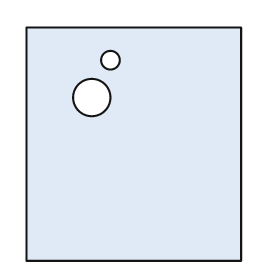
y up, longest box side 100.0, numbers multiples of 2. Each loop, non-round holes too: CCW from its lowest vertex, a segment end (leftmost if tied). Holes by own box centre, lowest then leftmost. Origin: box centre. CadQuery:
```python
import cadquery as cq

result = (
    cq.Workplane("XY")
    .moveTo(-46.0, -50.0)
    .lineTo(46.0, -50.0)
    .lineTo(46.0, 50.0)
    .lineTo(-46.0, 50.0)
    .close()
    .moveTo(-18.0, 20.0)
    .circle(8.0)
    .moveTo(-10.0, 36.0)
    .circle(4.0)
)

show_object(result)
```